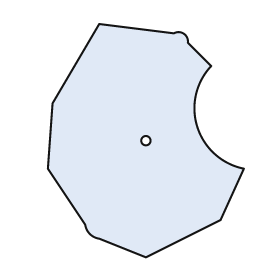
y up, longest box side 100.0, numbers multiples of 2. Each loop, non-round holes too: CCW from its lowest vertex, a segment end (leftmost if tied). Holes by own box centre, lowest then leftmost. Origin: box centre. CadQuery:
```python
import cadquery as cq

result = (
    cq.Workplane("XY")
    .moveTo(0.0, -50.0)
    .lineTo(32.0, -34.0)
    .lineTo(42.0, -12.0)
    .threePointArc((22.0, 6.0), (28.0, 32.0))
    .lineTo(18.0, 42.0)
    .threePointArc((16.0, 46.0), (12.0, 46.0))
    .lineTo(-20.0, 50.0)
    .lineTo(-40.0, 16.0)
    .lineTo(-42.0, -12.0)
    .lineTo(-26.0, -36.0)
    .threePointArc((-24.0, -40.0), (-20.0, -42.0))
    .close()
    .moveTo(0.0, 0.0)
    .circle(2.0)
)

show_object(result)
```